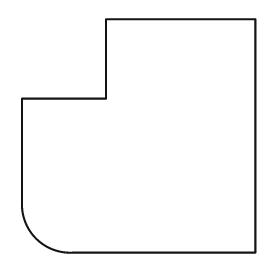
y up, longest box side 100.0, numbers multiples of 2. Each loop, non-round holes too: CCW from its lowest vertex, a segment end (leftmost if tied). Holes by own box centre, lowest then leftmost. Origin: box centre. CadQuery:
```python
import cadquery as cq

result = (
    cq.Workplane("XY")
    .moveTo(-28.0, -50.0)
    .lineTo(50.0, -50.0)
    .lineTo(50.0, 50.0)
    .lineTo(-14.0, 50.0)
    .lineTo(-14.0, 16.0)
    .lineTo(-50.0, 16.0)
    .lineTo(-50.0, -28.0)
    .threePointArc((-44.0, -44.0), (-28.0, -50.0))
    .close()
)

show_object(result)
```